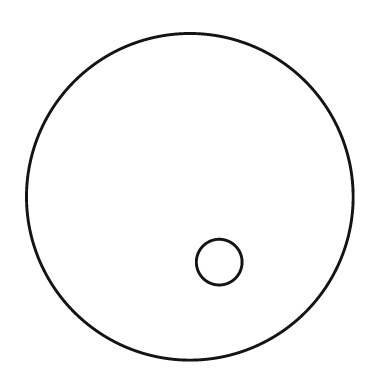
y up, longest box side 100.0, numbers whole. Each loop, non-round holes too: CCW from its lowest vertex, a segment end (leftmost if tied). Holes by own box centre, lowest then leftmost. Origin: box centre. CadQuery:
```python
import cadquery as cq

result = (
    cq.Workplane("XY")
    .moveTo(0.0, 0.0)
    .circle(50.0)
    .moveTo(9.0, -20.0)
    .circle(7.0)
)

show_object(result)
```